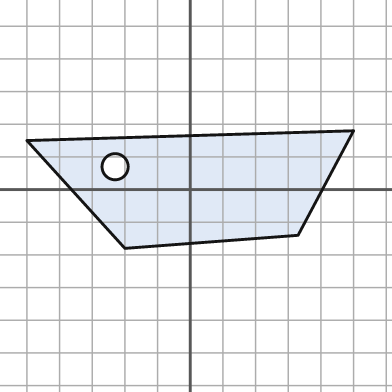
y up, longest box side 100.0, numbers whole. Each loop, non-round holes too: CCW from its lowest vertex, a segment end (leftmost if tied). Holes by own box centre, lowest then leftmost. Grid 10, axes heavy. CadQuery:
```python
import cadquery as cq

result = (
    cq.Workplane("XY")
    .moveTo(-20.0, -18.0)
    .lineTo(33.0, -14.0)
    .lineTo(50.0, 18.0)
    .lineTo(-50.0, 15.0)
    .close()
    .moveTo(-23.0, 7.0)
    .circle(4.0)
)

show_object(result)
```